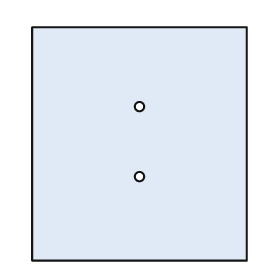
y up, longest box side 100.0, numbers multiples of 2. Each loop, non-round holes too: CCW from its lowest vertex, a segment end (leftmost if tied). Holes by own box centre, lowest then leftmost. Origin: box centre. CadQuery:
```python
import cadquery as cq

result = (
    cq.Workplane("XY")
    .moveTo(-46.0, -50.0)
    .lineTo(46.0, -50.0)
    .lineTo(46.0, 50.0)
    .lineTo(-46.0, 50.0)
    .close()
    .moveTo(0.0, -14.0)
    .circle(2.0)
    .moveTo(0.0, 16.0)
    .circle(2.0)
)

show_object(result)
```